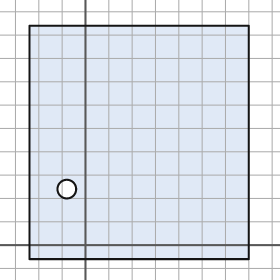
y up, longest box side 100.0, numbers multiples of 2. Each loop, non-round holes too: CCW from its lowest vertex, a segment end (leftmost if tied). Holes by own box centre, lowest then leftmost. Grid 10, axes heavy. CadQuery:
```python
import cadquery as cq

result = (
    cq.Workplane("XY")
    .moveTo(-24.0, -6.0)
    .lineTo(70.0, -6.0)
    .lineTo(70.0, 94.0)
    .lineTo(-24.0, 94.0)
    .close()
    .moveTo(-8.0, 24.0)
    .circle(4.0)
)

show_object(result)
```